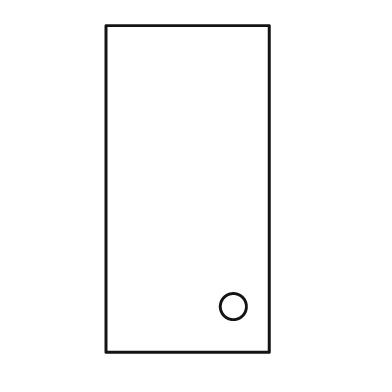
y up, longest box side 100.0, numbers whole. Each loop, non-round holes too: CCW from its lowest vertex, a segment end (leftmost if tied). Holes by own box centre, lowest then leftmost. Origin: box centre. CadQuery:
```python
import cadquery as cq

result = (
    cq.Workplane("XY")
    .moveTo(-25.0, -50.0)
    .lineTo(25.0, -50.0)
    .lineTo(25.0, 50.0)
    .lineTo(-25.0, 50.0)
    .close()
    .moveTo(14.0, -36.0)
    .circle(4.0)
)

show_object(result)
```